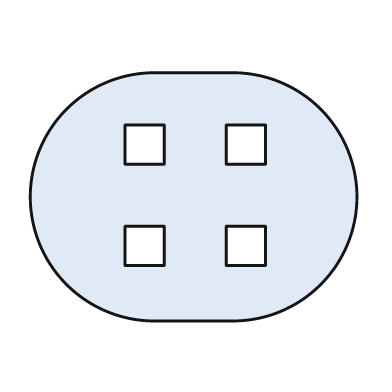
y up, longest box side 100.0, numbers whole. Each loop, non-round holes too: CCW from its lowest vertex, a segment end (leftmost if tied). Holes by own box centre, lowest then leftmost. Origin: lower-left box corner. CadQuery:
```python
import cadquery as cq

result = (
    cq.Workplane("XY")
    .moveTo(38.0, 0.0)
    .lineTo(62.0, 0.0)
    .threePointArc((100.0, 38.0), (62.0, 76.0))
    .lineTo(38.0, 76.0)
    .threePointArc((0.0, 38.0), (38.0, 0.0))
    .close()
    .moveTo(29.0, 17.0)
    .lineTo(41.0, 17.0)
    .lineTo(41.0, 29.0)
    .lineTo(29.0, 29.0)
    .close()
    .moveTo(60.0, 17.0)
    .lineTo(72.0, 17.0)
    .lineTo(72.0, 29.0)
    .lineTo(60.0, 29.0)
    .close()
    .moveTo(29.0, 48.0)
    .lineTo(41.0, 48.0)
    .lineTo(41.0, 60.0)
    .lineTo(29.0, 60.0)
    .close()
    .moveTo(60.0, 48.0)
    .lineTo(72.0, 48.0)
    .lineTo(72.0, 60.0)
    .lineTo(60.0, 60.0)
    .close()
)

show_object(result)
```